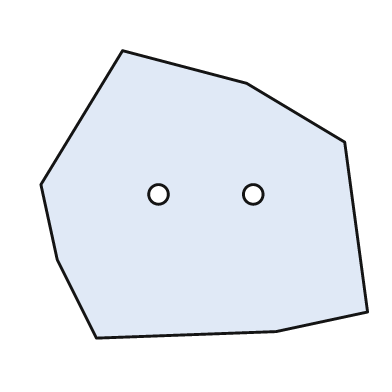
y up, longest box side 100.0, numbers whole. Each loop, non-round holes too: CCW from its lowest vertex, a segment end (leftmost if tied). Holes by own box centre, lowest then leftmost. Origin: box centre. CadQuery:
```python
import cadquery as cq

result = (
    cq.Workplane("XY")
    .moveTo(-33.0, -44.0)
    .lineTo(22.0, -42.0)
    .lineTo(50.0, -36.0)
    .lineTo(43.0, 16.0)
    .lineTo(13.0, 34.0)
    .lineTo(-25.0, 44.0)
    .lineTo(-50.0, 3.0)
    .lineTo(-45.0, -20.0)
    .close()
    .moveTo(-14.0, 0.0)
    .circle(3.0)
    .moveTo(15.0, 0.0)
    .circle(3.0)
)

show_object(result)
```